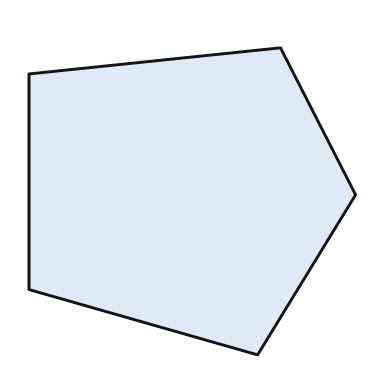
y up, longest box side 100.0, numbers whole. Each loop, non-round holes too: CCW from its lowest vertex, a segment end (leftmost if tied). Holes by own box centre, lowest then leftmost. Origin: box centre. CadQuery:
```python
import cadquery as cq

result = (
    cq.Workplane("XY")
    .moveTo(20.0, -47.0)
    .lineTo(50.0, 2.0)
    .lineTo(27.0, 47.0)
    .lineTo(-50.0, 39.0)
    .lineTo(-50.0, -27.0)
    .close()
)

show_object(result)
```